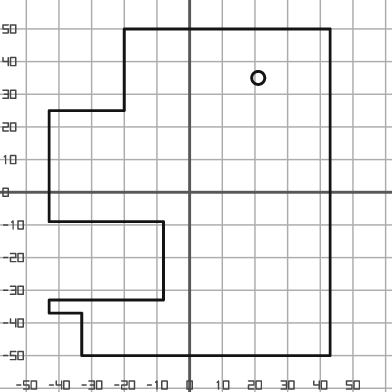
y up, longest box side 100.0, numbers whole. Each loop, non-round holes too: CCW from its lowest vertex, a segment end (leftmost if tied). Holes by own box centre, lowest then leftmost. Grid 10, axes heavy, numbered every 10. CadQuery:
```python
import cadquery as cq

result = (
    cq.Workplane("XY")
    .moveTo(-33.0, -50.0)
    .lineTo(43.0, -50.0)
    .lineTo(43.0, 50.0)
    .lineTo(-20.0, 50.0)
    .lineTo(-20.0, 25.0)
    .lineTo(-43.0, 25.0)
    .lineTo(-43.0, -9.0)
    .lineTo(-8.0, -9.0)
    .lineTo(-8.0, -33.0)
    .lineTo(-43.0, -33.0)
    .lineTo(-43.0, -37.0)
    .lineTo(-33.0, -37.0)
    .close()
    .moveTo(21.0, 35.0)
    .circle(2.0)
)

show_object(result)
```